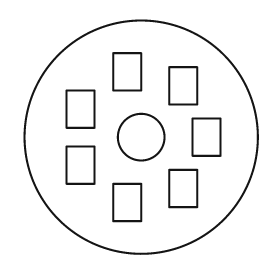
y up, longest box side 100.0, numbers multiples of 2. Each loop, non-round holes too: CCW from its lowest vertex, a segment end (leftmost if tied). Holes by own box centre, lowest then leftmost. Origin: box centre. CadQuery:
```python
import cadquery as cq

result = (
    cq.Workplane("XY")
    .moveTo(0.0, 0.0)
    .circle(50.0)
    .moveTo(-12.0, -36.0)
    .lineTo(0.0, -36.0)
    .lineTo(0.0, -20.0)
    .lineTo(-12.0, -20.0)
    .close()
    .moveTo(12.0, -30.0)
    .lineTo(24.0, -30.0)
    .lineTo(24.0, -14.0)
    .lineTo(12.0, -14.0)
    .close()
    .moveTo(-32.0, -20.0)
    .lineTo(-20.0, -20.0)
    .lineTo(-20.0, -4.0)
    .lineTo(-32.0, -4.0)
    .close()
    .moveTo(0.0, 0.0)
    .circle(10.0)
    .moveTo(22.0, -8.0)
    .lineTo(34.0, -8.0)
    .lineTo(34.0, 8.0)
    .lineTo(22.0, 8.0)
    .close()
    .moveTo(-32.0, 4.0)
    .lineTo(-20.0, 4.0)
    .lineTo(-20.0, 20.0)
    .lineTo(-32.0, 20.0)
    .close()
    .moveTo(12.0, 14.0)
    .lineTo(24.0, 14.0)
    .lineTo(24.0, 30.0)
    .lineTo(12.0, 30.0)
    .close()
    .moveTo(-12.0, 20.0)
    .lineTo(0.0, 20.0)
    .lineTo(0.0, 36.0)
    .lineTo(-12.0, 36.0)
    .close()
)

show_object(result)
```